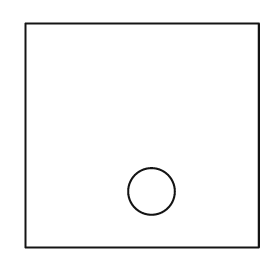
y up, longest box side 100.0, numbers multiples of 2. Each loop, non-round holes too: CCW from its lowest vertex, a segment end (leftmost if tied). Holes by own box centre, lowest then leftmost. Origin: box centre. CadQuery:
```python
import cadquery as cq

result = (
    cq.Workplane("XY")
    .moveTo(-50.0, -48.0)
    .lineTo(50.0, -48.0)
    .lineTo(50.0, 48.0)
    .lineTo(-50.0, 48.0)
    .close()
    .moveTo(4.0, -24.0)
    .circle(10.0)
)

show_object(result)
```